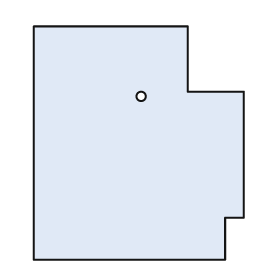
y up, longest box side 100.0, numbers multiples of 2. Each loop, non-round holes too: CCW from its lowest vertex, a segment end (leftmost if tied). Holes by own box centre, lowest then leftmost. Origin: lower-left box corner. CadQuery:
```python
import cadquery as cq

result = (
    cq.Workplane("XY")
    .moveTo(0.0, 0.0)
    .lineTo(82.0, 0.0)
    .lineTo(82.0, 18.0)
    .lineTo(90.0, 18.0)
    .lineTo(90.0, 72.0)
    .lineTo(66.0, 72.0)
    .lineTo(66.0, 100.0)
    .lineTo(0.0, 100.0)
    .close()
    .moveTo(46.0, 70.0)
    .circle(2.0)
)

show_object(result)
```